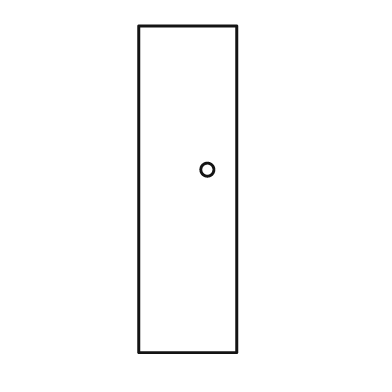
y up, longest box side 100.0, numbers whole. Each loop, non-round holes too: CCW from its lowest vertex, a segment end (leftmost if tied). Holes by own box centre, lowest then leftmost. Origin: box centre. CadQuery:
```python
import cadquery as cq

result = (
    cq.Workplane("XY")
    .moveTo(-15.0, -50.0)
    .lineTo(15.0, -50.0)
    .lineTo(15.0, 50.0)
    .lineTo(-15.0, 50.0)
    .close()
    .moveTo(6.0, 6.0)
    .circle(2.0)
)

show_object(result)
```